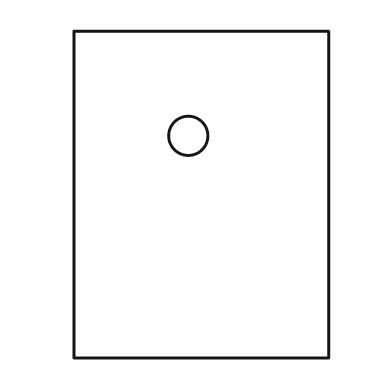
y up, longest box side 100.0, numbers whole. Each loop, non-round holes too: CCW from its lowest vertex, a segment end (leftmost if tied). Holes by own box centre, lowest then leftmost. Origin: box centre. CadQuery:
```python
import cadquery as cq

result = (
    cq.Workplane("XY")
    .moveTo(-39.0, -50.0)
    .lineTo(39.0, -50.0)
    .lineTo(39.0, 50.0)
    .lineTo(-39.0, 50.0)
    .close()
    .moveTo(-4.0, 18.0)
    .circle(6.0)
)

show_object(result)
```